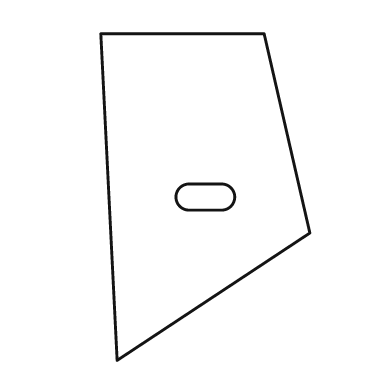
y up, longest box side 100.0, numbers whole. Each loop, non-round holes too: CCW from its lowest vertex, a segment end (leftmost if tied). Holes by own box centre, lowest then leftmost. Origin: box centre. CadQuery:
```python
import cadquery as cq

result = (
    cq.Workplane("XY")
    .moveTo(-27.0, -50.0)
    .lineTo(32.0, -11.0)
    .lineTo(18.0, 50.0)
    .lineTo(-32.0, 50.0)
    .close()
    .moveTo(-5.0, -4.0)
    .lineTo(5.0, -4.0)
    .threePointArc((9.0, 0.0), (5.0, 4.0))
    .lineTo(-5.0, 4.0)
    .threePointArc((-9.0, 0.0), (-5.0, -4.0))
    .close()
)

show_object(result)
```